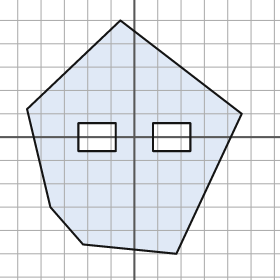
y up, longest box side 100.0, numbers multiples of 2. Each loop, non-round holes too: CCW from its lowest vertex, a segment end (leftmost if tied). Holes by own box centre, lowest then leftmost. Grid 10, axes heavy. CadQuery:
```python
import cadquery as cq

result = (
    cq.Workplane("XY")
    .moveTo(18.0, -50.0)
    .lineTo(46.0, 10.0)
    .lineTo(-6.0, 50.0)
    .lineTo(-46.0, 12.0)
    .lineTo(-36.0, -30.0)
    .lineTo(-22.0, -46.0)
    .close()
    .moveTo(-24.0, -6.0)
    .lineTo(-8.0, -6.0)
    .lineTo(-8.0, 6.0)
    .lineTo(-24.0, 6.0)
    .close()
    .moveTo(8.0, -6.0)
    .lineTo(24.0, -6.0)
    .lineTo(24.0, 6.0)
    .lineTo(8.0, 6.0)
    .close()
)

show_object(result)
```